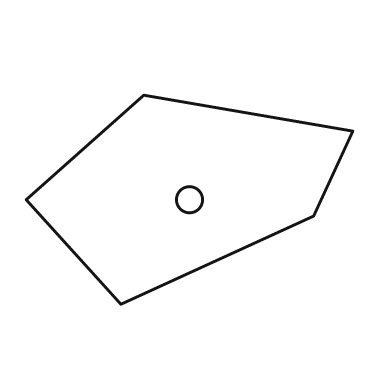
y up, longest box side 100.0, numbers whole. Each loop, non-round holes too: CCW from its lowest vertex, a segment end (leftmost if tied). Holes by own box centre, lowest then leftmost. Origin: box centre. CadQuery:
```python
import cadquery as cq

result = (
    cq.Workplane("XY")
    .moveTo(-21.0, -32.0)
    .lineTo(38.0, -5.0)
    .lineTo(50.0, 21.0)
    .lineTo(-14.0, 32.0)
    .lineTo(-50.0, 0.0)
    .close()
    .moveTo(0.0, 0.0)
    .circle(4.0)
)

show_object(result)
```